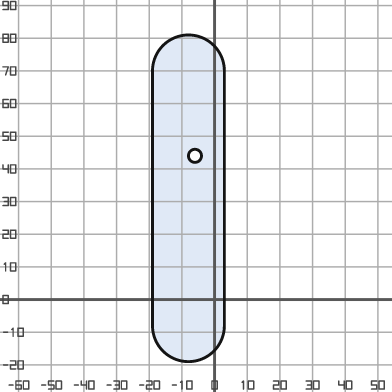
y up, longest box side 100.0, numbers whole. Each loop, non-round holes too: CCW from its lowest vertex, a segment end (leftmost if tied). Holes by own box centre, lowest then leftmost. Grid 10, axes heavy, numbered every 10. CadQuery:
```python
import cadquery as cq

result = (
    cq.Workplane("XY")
    .moveTo(-19.0, -8.0)
    .threePointArc((-8.0, -19.0), (3.0, -8.0))
    .lineTo(3.0, 70.0)
    .threePointArc((-8.0, 81.0), (-19.0, 70.0))
    .close()
    .moveTo(-6.0, 44.0)
    .circle(2.0)
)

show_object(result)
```